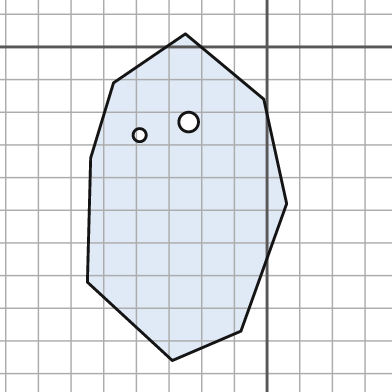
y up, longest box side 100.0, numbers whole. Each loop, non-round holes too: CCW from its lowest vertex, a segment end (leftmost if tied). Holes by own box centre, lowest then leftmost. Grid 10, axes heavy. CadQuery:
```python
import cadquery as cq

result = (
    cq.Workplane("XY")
    .moveTo(-29.0, -96.0)
    .lineTo(-8.0, -87.0)
    .lineTo(6.0, -48.0)
    .lineTo(-1.0, -16.0)
    .lineTo(-25.0, 4.0)
    .lineTo(-47.0, -11.0)
    .lineTo(-54.0, -34.0)
    .lineTo(-55.0, -72.0)
    .close()
    .moveTo(-39.0, -27.0)
    .circle(2.0)
    .moveTo(-24.0, -23.0)
    .circle(3.0)
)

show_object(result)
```